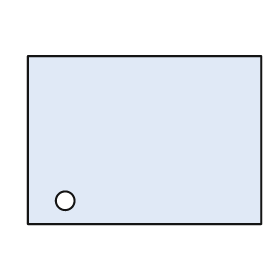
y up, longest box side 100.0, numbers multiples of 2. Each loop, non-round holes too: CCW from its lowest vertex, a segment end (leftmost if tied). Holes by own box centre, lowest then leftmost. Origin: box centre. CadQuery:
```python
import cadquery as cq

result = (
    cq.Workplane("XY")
    .moveTo(-50.0, -36.0)
    .lineTo(50.0, -36.0)
    .lineTo(50.0, 36.0)
    .lineTo(-50.0, 36.0)
    .close()
    .moveTo(-34.0, -26.0)
    .circle(4.0)
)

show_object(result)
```